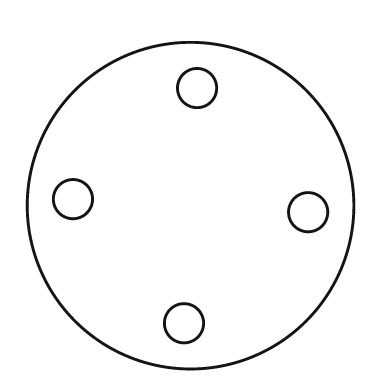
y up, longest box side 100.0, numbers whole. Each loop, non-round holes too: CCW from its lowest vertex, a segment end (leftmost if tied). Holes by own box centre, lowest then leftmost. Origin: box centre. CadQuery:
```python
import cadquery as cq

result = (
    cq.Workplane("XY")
    .moveTo(0.0, 0.0)
    .circle(50.0)
    .moveTo(-2.0, -36.0)
    .circle(6.0)
    .moveTo(36.0, -2.0)
    .circle(6.0)
    .moveTo(-36.0, 2.0)
    .circle(6.0)
    .moveTo(2.0, 36.0)
    .circle(6.0)
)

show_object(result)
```